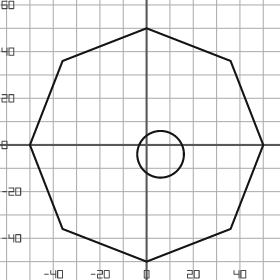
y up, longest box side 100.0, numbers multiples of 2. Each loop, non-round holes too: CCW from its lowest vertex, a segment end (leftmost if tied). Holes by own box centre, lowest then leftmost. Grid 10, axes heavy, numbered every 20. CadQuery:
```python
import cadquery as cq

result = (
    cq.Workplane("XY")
    .moveTo(0.0, -50.0)
    .lineTo(36.0, -36.0)
    .lineTo(50.0, 0.0)
    .lineTo(36.0, 36.0)
    .lineTo(0.0, 50.0)
    .lineTo(-36.0, 36.0)
    .lineTo(-50.0, 0.0)
    .lineTo(-36.0, -36.0)
    .close()
    .moveTo(6.0, -4.0)
    .circle(10.0)
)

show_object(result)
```